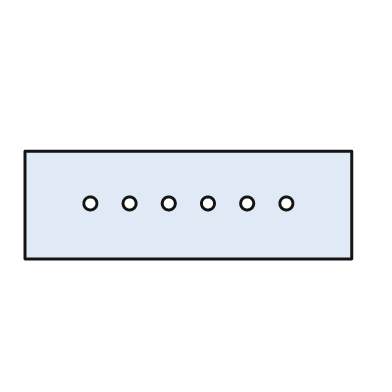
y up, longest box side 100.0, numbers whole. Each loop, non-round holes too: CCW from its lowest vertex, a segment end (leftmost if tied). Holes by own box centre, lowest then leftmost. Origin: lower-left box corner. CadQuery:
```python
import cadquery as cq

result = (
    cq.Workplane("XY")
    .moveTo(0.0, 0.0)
    .lineTo(100.0, 0.0)
    .lineTo(100.0, 33.0)
    .lineTo(0.0, 33.0)
    .close()
    .moveTo(20.0, 17.0)
    .circle(2.0)
    .moveTo(32.0, 17.0)
    .circle(2.0)
    .moveTo(44.0, 17.0)
    .circle(2.0)
    .moveTo(56.0, 17.0)
    .circle(2.0)
    .moveTo(68.0, 17.0)
    .circle(2.0)
    .moveTo(80.0, 17.0)
    .circle(2.0)
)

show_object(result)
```